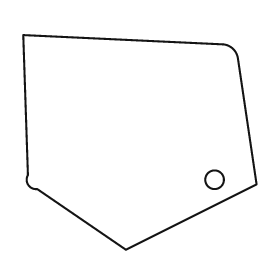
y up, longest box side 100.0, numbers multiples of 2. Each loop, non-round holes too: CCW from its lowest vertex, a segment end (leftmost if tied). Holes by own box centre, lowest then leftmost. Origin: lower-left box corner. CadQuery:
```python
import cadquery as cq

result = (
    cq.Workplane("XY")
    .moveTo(44.0, 0.0)
    .lineTo(100.0, 28.0)
    .lineTo(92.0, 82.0)
    .threePointArc((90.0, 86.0), (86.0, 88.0))
    .lineTo(0.0, 92.0)
    .lineTo(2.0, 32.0)
    .threePointArc((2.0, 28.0), (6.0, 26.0))
    .close()
    .moveTo(82.0, 30.0)
    .circle(4.0)
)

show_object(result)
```